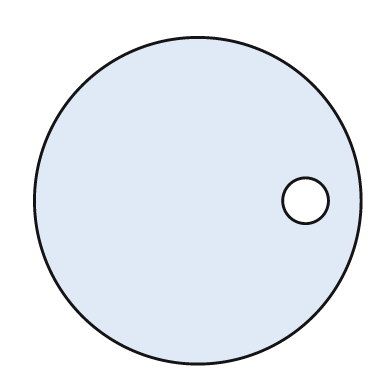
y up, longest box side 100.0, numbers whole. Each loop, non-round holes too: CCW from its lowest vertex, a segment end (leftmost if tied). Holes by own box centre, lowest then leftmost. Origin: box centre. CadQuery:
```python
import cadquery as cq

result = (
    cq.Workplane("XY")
    .moveTo(0.0, 0.0)
    .circle(50.0)
    .moveTo(33.0, 0.0)
    .circle(7.0)
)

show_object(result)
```